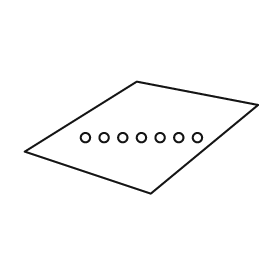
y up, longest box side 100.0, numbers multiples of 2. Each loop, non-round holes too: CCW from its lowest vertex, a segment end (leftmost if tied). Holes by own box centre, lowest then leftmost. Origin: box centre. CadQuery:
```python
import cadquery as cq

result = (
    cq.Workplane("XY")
    .moveTo(4.0, -24.0)
    .lineTo(50.0, 14.0)
    .lineTo(-2.0, 24.0)
    .lineTo(-50.0, -6.0)
    .close()
    .moveTo(-24.0, 0.0)
    .circle(2.0)
    .moveTo(-16.0, 0.0)
    .circle(2.0)
    .moveTo(-8.0, 0.0)
    .circle(2.0)
    .moveTo(0.0, 0.0)
    .circle(2.0)
    .moveTo(8.0, 0.0)
    .circle(2.0)
    .moveTo(16.0, 0.0)
    .circle(2.0)
    .moveTo(24.0, 0.0)
    .circle(2.0)
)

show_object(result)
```